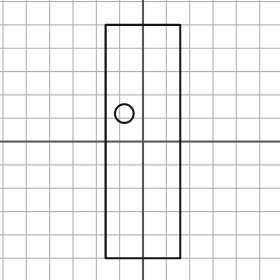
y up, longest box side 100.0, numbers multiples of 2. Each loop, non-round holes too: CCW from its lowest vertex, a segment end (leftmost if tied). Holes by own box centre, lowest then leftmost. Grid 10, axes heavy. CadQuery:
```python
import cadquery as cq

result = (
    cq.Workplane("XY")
    .moveTo(-16.0, -50.0)
    .lineTo(16.0, -50.0)
    .lineTo(16.0, 50.0)
    .lineTo(-16.0, 50.0)
    .close()
    .moveTo(-8.0, 12.0)
    .circle(4.0)
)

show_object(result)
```